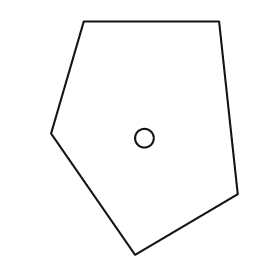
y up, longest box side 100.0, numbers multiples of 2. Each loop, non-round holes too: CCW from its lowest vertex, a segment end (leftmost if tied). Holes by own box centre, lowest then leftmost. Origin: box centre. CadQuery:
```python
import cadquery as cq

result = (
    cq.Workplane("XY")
    .moveTo(-4.0, -50.0)
    .lineTo(40.0, -24.0)
    .lineTo(32.0, 50.0)
    .lineTo(-26.0, 50.0)
    .lineTo(-40.0, 2.0)
    .close()
    .moveTo(0.0, 0.0)
    .circle(4.0)
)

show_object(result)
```